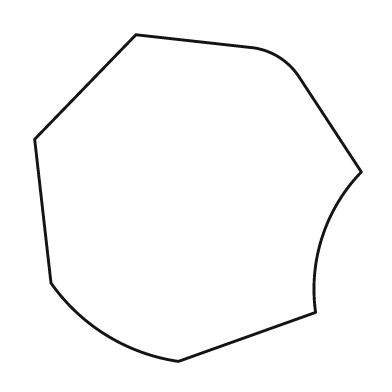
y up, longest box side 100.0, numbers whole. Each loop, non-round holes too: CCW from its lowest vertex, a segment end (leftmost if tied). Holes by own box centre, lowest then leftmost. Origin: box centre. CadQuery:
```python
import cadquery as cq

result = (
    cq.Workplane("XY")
    .moveTo(-6.0, -50.0)
    .lineTo(36.0, -35.0)
    .threePointArc((38.0, -12.0), (50.0, 8.0))
    .lineTo(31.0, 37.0)
    .threePointArc((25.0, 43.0), (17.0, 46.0))
    .lineTo(-19.0, 50.0)
    .lineTo(-50.0, 18.0)
    .lineTo(-45.0, -26.0)
    .threePointArc((-28.0, -42.0), (-6.0, -50.0))
    .close()
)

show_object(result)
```